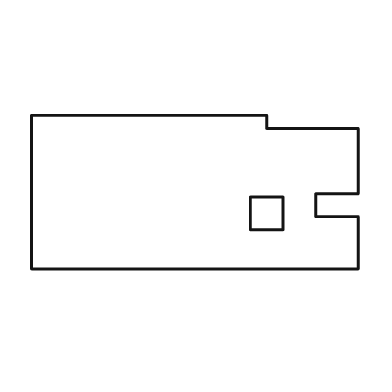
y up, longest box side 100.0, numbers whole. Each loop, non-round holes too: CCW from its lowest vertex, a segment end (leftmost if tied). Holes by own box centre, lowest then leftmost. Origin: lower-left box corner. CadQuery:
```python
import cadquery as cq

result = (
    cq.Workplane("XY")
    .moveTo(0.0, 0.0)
    .lineTo(100.0, 0.0)
    .lineTo(100.0, 16.0)
    .lineTo(87.0, 16.0)
    .lineTo(87.0, 23.0)
    .lineTo(100.0, 23.0)
    .lineTo(100.0, 43.0)
    .lineTo(72.0, 43.0)
    .lineTo(72.0, 47.0)
    .lineTo(0.0, 47.0)
    .close()
    .moveTo(67.0, 12.0)
    .lineTo(77.0, 12.0)
    .lineTo(77.0, 22.0)
    .lineTo(67.0, 22.0)
    .close()
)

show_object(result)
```